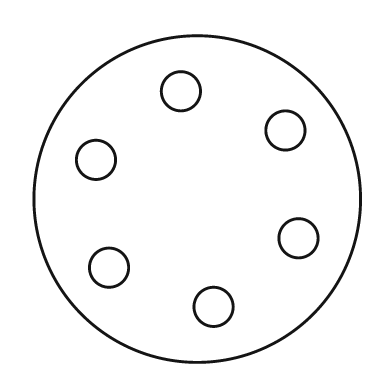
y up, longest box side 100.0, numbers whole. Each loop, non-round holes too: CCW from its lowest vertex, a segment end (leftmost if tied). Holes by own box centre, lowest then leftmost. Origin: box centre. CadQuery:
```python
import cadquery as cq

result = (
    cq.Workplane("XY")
    .moveTo(0.0, 0.0)
    .circle(50.0)
    .moveTo(5.0, -33.0)
    .circle(6.0)
    .moveTo(-27.0, -21.0)
    .circle(6.0)
    .moveTo(31.0, -12.0)
    .circle(6.0)
    .moveTo(-31.0, 12.0)
    .circle(6.0)
    .moveTo(27.0, 21.0)
    .circle(6.0)
    .moveTo(-5.0, 33.0)
    .circle(6.0)
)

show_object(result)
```